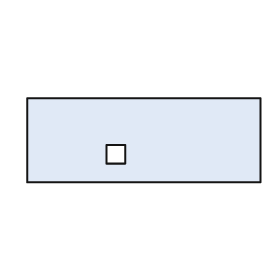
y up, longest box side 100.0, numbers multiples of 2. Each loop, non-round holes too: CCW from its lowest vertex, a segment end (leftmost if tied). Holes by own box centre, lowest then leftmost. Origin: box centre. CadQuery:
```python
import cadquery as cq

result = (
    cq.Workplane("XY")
    .moveTo(-50.0, -18.0)
    .lineTo(50.0, -18.0)
    .lineTo(50.0, 18.0)
    .lineTo(-50.0, 18.0)
    .close()
    .moveTo(-16.0, -10.0)
    .lineTo(-8.0, -10.0)
    .lineTo(-8.0, -2.0)
    .lineTo(-16.0, -2.0)
    .close()
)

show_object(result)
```